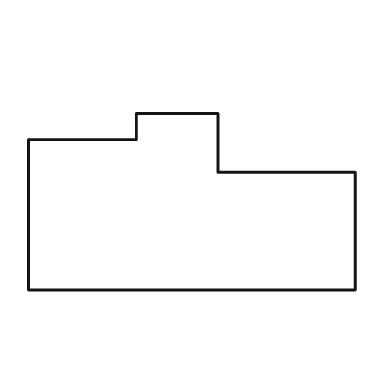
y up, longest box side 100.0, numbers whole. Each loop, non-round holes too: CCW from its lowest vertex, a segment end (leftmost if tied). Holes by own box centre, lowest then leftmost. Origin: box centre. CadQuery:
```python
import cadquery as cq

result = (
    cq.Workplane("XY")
    .moveTo(-50.0, -27.0)
    .lineTo(50.0, -27.0)
    .lineTo(50.0, 9.0)
    .lineTo(8.0, 9.0)
    .lineTo(8.0, 27.0)
    .lineTo(-17.0, 27.0)
    .lineTo(-17.0, 19.0)
    .lineTo(-50.0, 19.0)
    .close()
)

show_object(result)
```